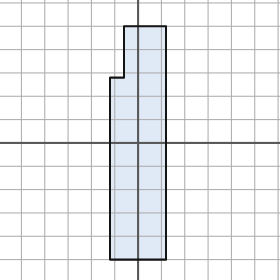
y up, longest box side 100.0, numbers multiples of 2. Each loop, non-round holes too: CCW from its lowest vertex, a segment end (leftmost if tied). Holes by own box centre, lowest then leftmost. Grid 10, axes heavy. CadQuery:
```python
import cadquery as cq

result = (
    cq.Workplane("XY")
    .moveTo(-12.0, -50.0)
    .lineTo(12.0, -50.0)
    .lineTo(12.0, 50.0)
    .lineTo(-6.0, 50.0)
    .lineTo(-6.0, 28.0)
    .lineTo(-12.0, 28.0)
    .close()
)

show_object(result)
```